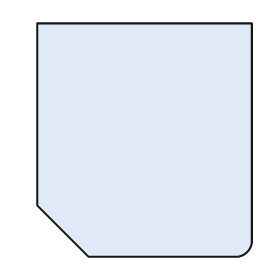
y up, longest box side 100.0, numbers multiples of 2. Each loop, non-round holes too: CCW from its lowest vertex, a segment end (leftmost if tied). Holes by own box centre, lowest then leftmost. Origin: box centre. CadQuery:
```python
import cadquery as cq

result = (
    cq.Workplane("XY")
    .moveTo(-24.0, -50.0)
    .lineTo(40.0, -50.0)
    .threePointArc((44.0, -48.0), (46.0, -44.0))
    .lineTo(46.0, 50.0)
    .lineTo(-46.0, 50.0)
    .lineTo(-46.0, -28.0)
    .close()
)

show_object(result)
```